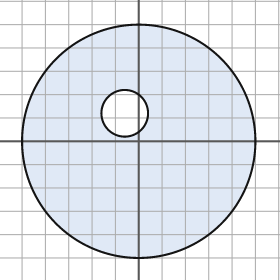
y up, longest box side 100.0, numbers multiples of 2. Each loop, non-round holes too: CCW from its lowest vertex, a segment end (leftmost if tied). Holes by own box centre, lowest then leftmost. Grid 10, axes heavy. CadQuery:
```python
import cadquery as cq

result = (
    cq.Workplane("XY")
    .moveTo(0.0, 0.0)
    .circle(50.0)
    .moveTo(-6.0, 12.0)
    .circle(10.0)
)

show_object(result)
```